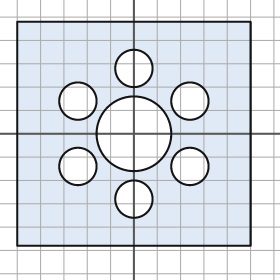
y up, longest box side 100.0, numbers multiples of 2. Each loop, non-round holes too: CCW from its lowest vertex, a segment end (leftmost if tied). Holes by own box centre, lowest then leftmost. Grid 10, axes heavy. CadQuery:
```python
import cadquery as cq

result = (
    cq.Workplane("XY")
    .moveTo(-50.0, -48.0)
    .lineTo(50.0, -48.0)
    .lineTo(50.0, 48.0)
    .lineTo(-50.0, 48.0)
    .close()
    .moveTo(0.0, -28.0)
    .circle(8.0)
    .moveTo(-24.0, -14.0)
    .circle(8.0)
    .moveTo(24.0, -14.0)
    .circle(8.0)
    .moveTo(0.0, 0.0)
    .circle(16.0)
    .moveTo(-24.0, 14.0)
    .circle(8.0)
    .moveTo(24.0, 14.0)
    .circle(8.0)
    .moveTo(0.0, 28.0)
    .circle(8.0)
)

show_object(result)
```